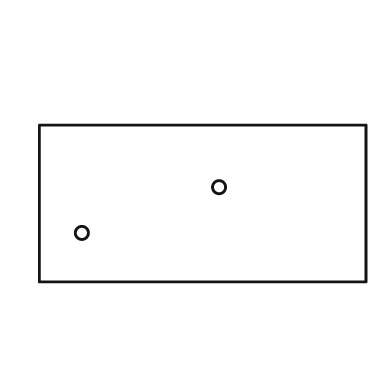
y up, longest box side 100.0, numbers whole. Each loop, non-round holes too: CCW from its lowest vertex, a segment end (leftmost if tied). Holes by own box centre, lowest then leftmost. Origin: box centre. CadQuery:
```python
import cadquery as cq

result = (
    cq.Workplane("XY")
    .moveTo(-50.0, -24.0)
    .lineTo(50.0, -24.0)
    .lineTo(50.0, 24.0)
    .lineTo(-50.0, 24.0)
    .close()
    .moveTo(-37.0, -9.0)
    .circle(2.0)
    .moveTo(5.0, 5.0)
    .circle(2.0)
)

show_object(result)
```